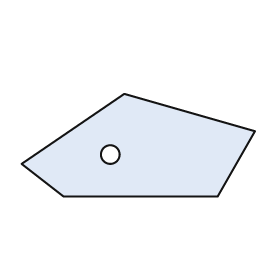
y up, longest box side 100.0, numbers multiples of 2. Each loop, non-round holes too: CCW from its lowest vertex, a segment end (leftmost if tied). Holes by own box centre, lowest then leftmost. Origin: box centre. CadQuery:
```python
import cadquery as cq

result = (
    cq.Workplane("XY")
    .moveTo(-32.0, -22.0)
    .lineTo(34.0, -22.0)
    .lineTo(50.0, 6.0)
    .lineTo(-6.0, 22.0)
    .lineTo(-50.0, -8.0)
    .close()
    .moveTo(-12.0, -4.0)
    .circle(4.0)
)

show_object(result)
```